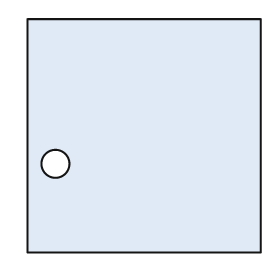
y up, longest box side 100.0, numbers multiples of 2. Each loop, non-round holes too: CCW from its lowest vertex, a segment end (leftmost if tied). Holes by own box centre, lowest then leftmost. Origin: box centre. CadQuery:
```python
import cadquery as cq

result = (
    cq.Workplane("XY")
    .moveTo(-50.0, -50.0)
    .lineTo(50.0, -50.0)
    .lineTo(50.0, 50.0)
    .lineTo(-50.0, 50.0)
    .close()
    .moveTo(-38.0, -12.0)
    .circle(6.0)
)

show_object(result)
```